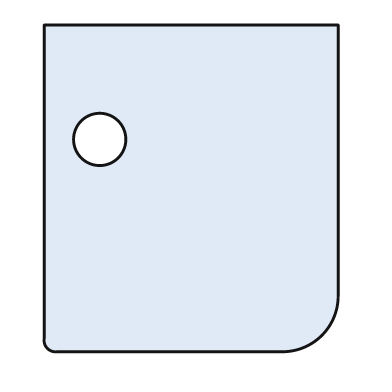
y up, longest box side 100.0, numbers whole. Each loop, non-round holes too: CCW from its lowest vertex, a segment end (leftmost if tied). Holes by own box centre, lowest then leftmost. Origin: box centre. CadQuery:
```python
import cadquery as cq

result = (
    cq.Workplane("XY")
    .moveTo(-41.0, -50.0)
    .lineTo(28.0, -50.0)
    .threePointArc((40.0, -45.0), (45.0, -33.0))
    .lineTo(45.0, 50.0)
    .lineTo(-45.0, 50.0)
    .lineTo(-45.0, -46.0)
    .threePointArc((-44.0, -49.0), (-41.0, -50.0))
    .close()
    .moveTo(-28.0, 15.0)
    .circle(8.0)
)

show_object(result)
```